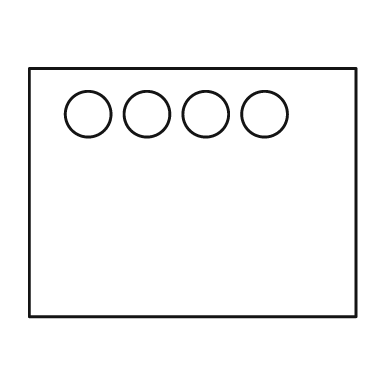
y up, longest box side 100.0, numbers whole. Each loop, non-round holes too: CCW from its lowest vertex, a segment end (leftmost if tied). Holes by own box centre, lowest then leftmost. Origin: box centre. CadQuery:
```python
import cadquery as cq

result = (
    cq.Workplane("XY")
    .moveTo(-50.0, -38.0)
    .lineTo(50.0, -38.0)
    .lineTo(50.0, 38.0)
    .lineTo(-50.0, 38.0)
    .close()
    .moveTo(-32.0, 24.0)
    .circle(7.0)
    .moveTo(-14.0, 24.0)
    .circle(7.0)
    .moveTo(4.0, 24.0)
    .circle(7.0)
    .moveTo(22.0, 24.0)
    .circle(7.0)
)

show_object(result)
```